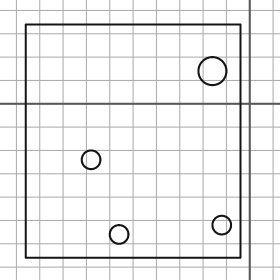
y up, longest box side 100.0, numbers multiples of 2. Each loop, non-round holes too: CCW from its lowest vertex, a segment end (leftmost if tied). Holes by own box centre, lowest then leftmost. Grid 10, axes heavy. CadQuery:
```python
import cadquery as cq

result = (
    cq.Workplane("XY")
    .moveTo(-96.0, -66.0)
    .lineTo(-4.0, -66.0)
    .lineTo(-4.0, 34.0)
    .lineTo(-96.0, 34.0)
    .close()
    .moveTo(-56.0, -56.0)
    .circle(4.0)
    .moveTo(-12.0, -52.0)
    .circle(4.0)
    .moveTo(-68.0, -24.0)
    .circle(4.0)
    .moveTo(-16.0, 14.0)
    .circle(6.0)
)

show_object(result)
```